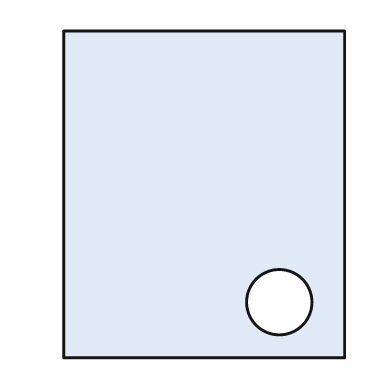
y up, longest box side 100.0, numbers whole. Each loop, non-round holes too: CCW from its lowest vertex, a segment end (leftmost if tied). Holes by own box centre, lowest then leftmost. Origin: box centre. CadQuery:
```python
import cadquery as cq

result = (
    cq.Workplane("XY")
    .moveTo(-43.0, -50.0)
    .lineTo(43.0, -50.0)
    .lineTo(43.0, 50.0)
    .lineTo(-43.0, 50.0)
    .close()
    .moveTo(23.0, -33.0)
    .circle(10.0)
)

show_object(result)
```